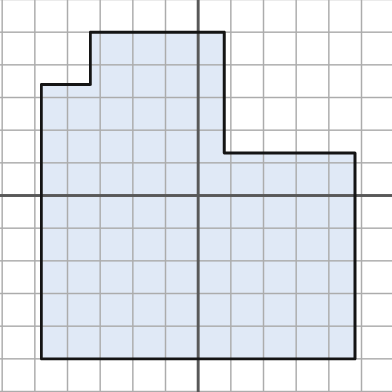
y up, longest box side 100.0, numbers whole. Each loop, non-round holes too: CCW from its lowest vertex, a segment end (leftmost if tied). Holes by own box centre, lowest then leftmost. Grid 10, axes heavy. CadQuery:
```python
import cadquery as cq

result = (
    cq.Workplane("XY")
    .moveTo(-48.0, -50.0)
    .lineTo(48.0, -50.0)
    .lineTo(48.0, 13.0)
    .lineTo(8.0, 13.0)
    .lineTo(8.0, 50.0)
    .lineTo(-33.0, 50.0)
    .lineTo(-33.0, 34.0)
    .lineTo(-48.0, 34.0)
    .close()
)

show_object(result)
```